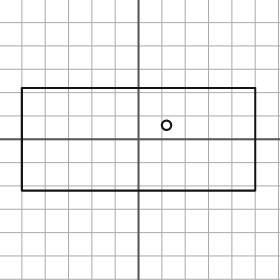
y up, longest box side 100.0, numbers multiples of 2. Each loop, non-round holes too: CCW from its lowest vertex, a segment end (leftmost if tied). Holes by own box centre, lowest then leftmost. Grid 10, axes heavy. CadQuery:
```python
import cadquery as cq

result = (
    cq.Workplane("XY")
    .moveTo(-50.0, -22.0)
    .lineTo(50.0, -22.0)
    .lineTo(50.0, 22.0)
    .lineTo(-50.0, 22.0)
    .close()
    .moveTo(12.0, 6.0)
    .circle(2.0)
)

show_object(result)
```